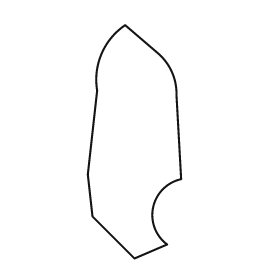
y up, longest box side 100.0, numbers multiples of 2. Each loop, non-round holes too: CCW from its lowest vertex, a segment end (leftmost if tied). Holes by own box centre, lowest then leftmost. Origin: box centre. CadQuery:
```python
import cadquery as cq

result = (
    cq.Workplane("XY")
    .moveTo(0.0, -50.0)
    .lineTo(14.0, -44.0)
    .threePointArc((8.0, -28.0), (20.0, -16.0))
    .lineTo(18.0, 20.0)
    .threePointArc((16.0, 30.0), (10.0, 38.0))
    .lineTo(-4.0, 50.0)
    .threePointArc((-14.0, 38.0), (-16.0, 22.0))
    .lineTo(-20.0, -14.0)
    .lineTo(-18.0, -32.0)
    .close()
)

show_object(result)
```